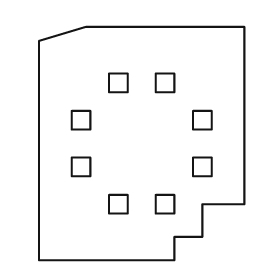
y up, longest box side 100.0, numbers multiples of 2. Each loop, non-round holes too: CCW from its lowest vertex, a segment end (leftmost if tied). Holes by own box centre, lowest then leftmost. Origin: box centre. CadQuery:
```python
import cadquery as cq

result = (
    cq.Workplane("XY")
    .moveTo(-44.0, -50.0)
    .lineTo(14.0, -50.0)
    .lineTo(14.0, -40.0)
    .lineTo(26.0, -40.0)
    .lineTo(26.0, -26.0)
    .lineTo(44.0, -26.0)
    .lineTo(44.0, 50.0)
    .lineTo(-24.0, 50.0)
    .lineTo(-44.0, 44.0)
    .close()
    .moveTo(-14.0, -30.0)
    .lineTo(-6.0, -30.0)
    .lineTo(-6.0, -22.0)
    .lineTo(-14.0, -22.0)
    .close()
    .moveTo(6.0, -30.0)
    .lineTo(14.0, -30.0)
    .lineTo(14.0, -22.0)
    .lineTo(6.0, -22.0)
    .close()
    .moveTo(-30.0, -14.0)
    .lineTo(-22.0, -14.0)
    .lineTo(-22.0, -6.0)
    .lineTo(-30.0, -6.0)
    .close()
    .moveTo(22.0, -14.0)
    .lineTo(30.0, -14.0)
    .lineTo(30.0, -6.0)
    .lineTo(22.0, -6.0)
    .close()
    .moveTo(-30.0, 6.0)
    .lineTo(-22.0, 6.0)
    .lineTo(-22.0, 14.0)
    .lineTo(-30.0, 14.0)
    .close()
    .moveTo(22.0, 6.0)
    .lineTo(30.0, 6.0)
    .lineTo(30.0, 14.0)
    .lineTo(22.0, 14.0)
    .close()
    .moveTo(-14.0, 22.0)
    .lineTo(-6.0, 22.0)
    .lineTo(-6.0, 30.0)
    .lineTo(-14.0, 30.0)
    .close()
    .moveTo(6.0, 22.0)
    .lineTo(14.0, 22.0)
    .lineTo(14.0, 30.0)
    .lineTo(6.0, 30.0)
    .close()
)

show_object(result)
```